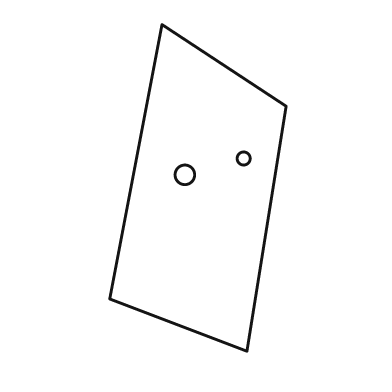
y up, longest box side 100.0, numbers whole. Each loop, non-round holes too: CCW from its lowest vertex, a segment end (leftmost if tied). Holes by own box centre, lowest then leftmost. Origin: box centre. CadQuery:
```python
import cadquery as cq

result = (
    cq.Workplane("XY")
    .moveTo(15.0, -50.0)
    .lineTo(27.0, 25.0)
    .lineTo(-11.0, 50.0)
    .lineTo(-27.0, -34.0)
    .close()
    .moveTo(-4.0, 4.0)
    .circle(3.0)
    .moveTo(14.0, 9.0)
    .circle(2.0)
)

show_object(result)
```